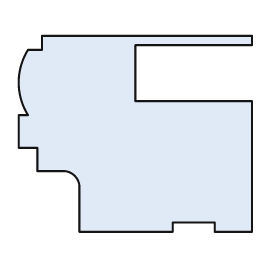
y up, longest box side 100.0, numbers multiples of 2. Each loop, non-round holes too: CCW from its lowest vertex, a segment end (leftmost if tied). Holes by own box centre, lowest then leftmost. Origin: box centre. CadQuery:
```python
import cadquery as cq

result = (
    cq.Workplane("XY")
    .moveTo(-24.0, -42.0)
    .lineTo(16.0, -42.0)
    .lineTo(16.0, -38.0)
    .lineTo(34.0, -38.0)
    .lineTo(34.0, -42.0)
    .lineTo(50.0, -42.0)
    .lineTo(50.0, 14.0)
    .lineTo(0.0, 14.0)
    .lineTo(0.0, 38.0)
    .lineTo(50.0, 38.0)
    .lineTo(50.0, 42.0)
    .lineTo(-40.0, 42.0)
    .lineTo(-40.0, 36.0)
    .lineTo(-46.0, 36.0)
    .threePointArc((-50.0, 22.0), (-46.0, 8.0))
    .lineTo(-50.0, 8.0)
    .lineTo(-50.0, -6.0)
    .lineTo(-42.0, -6.0)
    .lineTo(-42.0, -16.0)
    .lineTo(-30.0, -16.0)
    .threePointArc((-26.0, -18.0), (-24.0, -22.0))
    .close()
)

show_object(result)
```